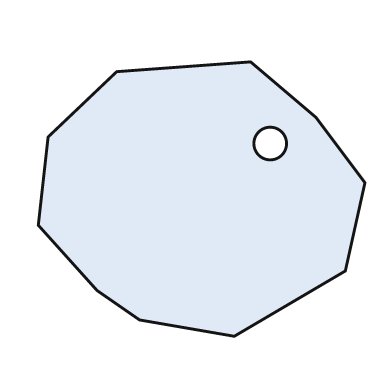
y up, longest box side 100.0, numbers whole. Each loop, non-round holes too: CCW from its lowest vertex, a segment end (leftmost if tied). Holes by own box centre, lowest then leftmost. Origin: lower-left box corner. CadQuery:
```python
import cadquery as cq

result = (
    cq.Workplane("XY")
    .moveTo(60.0, 0.0)
    .lineTo(94.0, 20.0)
    .lineTo(100.0, 47.0)
    .lineTo(85.0, 67.0)
    .lineTo(65.0, 84.0)
    .lineTo(24.0, 81.0)
    .lineTo(3.0, 61.0)
    .lineTo(0.0, 34.0)
    .lineTo(18.0, 14.0)
    .lineTo(31.0, 5.0)
    .close()
    .moveTo(71.0, 59.0)
    .circle(5.0)
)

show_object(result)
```